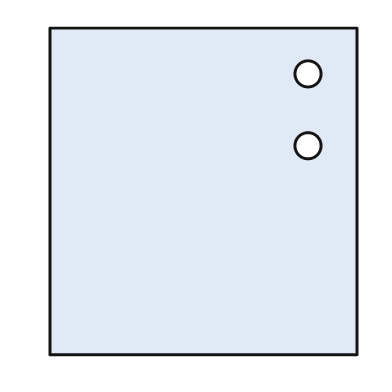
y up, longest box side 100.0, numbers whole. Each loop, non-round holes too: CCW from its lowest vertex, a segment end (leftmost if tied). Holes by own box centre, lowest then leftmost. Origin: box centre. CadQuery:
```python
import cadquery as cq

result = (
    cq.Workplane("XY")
    .moveTo(-47.0, -50.0)
    .lineTo(47.0, -50.0)
    .lineTo(47.0, 50.0)
    .lineTo(-47.0, 50.0)
    .close()
    .moveTo(32.0, 14.0)
    .circle(4.0)
    .moveTo(32.0, 36.0)
    .circle(4.0)
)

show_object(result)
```